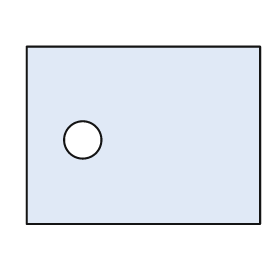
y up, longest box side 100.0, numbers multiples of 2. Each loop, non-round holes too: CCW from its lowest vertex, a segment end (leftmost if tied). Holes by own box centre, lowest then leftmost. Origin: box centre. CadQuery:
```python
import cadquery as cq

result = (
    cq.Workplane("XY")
    .moveTo(-50.0, -38.0)
    .lineTo(50.0, -38.0)
    .lineTo(50.0, 38.0)
    .lineTo(-50.0, 38.0)
    .close()
    .moveTo(-26.0, -2.0)
    .circle(8.0)
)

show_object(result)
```